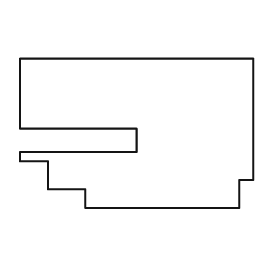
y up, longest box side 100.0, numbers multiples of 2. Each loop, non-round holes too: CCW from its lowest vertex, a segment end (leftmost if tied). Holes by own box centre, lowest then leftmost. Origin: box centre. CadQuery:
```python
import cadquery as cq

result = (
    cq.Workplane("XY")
    .moveTo(-22.0, -32.0)
    .lineTo(44.0, -32.0)
    .lineTo(44.0, -20.0)
    .lineTo(50.0, -20.0)
    .lineTo(50.0, 32.0)
    .lineTo(-50.0, 32.0)
    .lineTo(-50.0, 2.0)
    .lineTo(0.0, 2.0)
    .lineTo(0.0, -8.0)
    .lineTo(-50.0, -8.0)
    .lineTo(-50.0, -12.0)
    .lineTo(-38.0, -12.0)
    .lineTo(-38.0, -24.0)
    .lineTo(-22.0, -24.0)
    .close()
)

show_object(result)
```